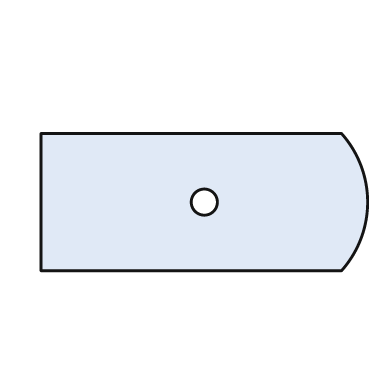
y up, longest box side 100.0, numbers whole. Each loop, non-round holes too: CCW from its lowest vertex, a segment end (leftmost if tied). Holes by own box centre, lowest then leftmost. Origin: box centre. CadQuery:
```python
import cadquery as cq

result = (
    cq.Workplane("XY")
    .moveTo(-50.0, -21.0)
    .lineTo(42.0, -21.0)
    .threePointArc((50.0, 0.0), (42.0, 21.0))
    .lineTo(-50.0, 21.0)
    .close()
    .moveTo(0.0, 0.0)
    .circle(4.0)
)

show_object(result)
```